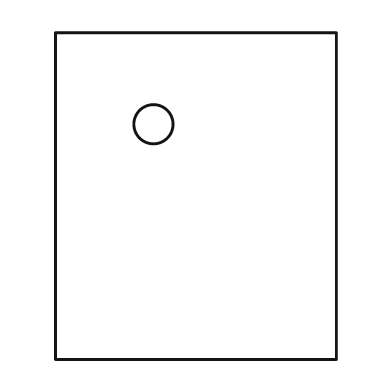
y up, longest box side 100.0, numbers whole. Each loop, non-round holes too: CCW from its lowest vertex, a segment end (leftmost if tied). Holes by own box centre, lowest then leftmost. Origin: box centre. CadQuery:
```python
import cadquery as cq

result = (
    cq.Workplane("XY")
    .moveTo(-43.0, -50.0)
    .lineTo(43.0, -50.0)
    .lineTo(43.0, 50.0)
    .lineTo(-43.0, 50.0)
    .close()
    .moveTo(-13.0, 22.0)
    .circle(6.0)
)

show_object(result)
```